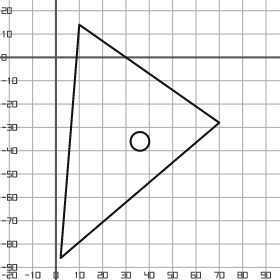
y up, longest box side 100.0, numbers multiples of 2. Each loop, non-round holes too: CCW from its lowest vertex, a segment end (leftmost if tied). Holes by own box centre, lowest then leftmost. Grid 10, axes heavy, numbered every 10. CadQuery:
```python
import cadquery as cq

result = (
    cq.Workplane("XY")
    .moveTo(2.0, -86.0)
    .lineTo(70.0, -28.0)
    .lineTo(10.0, 14.0)
    .close()
    .moveTo(36.0, -36.0)
    .circle(4.0)
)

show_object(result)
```